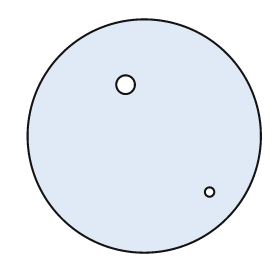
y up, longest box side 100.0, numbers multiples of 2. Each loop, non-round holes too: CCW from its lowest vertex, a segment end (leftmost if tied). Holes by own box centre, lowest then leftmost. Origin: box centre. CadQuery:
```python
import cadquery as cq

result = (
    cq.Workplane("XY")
    .moveTo(0.0, 0.0)
    .circle(50.0)
    .moveTo(28.0, -24.0)
    .circle(2.0)
    .moveTo(-8.0, 22.0)
    .circle(4.0)
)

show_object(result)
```